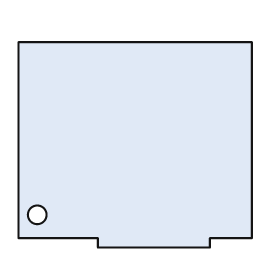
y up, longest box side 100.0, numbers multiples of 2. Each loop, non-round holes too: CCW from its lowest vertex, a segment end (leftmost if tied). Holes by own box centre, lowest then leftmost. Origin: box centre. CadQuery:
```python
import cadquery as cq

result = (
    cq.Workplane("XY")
    .moveTo(-16.0, -44.0)
    .lineTo(32.0, -44.0)
    .lineTo(32.0, -40.0)
    .lineTo(50.0, -40.0)
    .lineTo(50.0, 44.0)
    .lineTo(-50.0, 44.0)
    .lineTo(-50.0, -40.0)
    .lineTo(-16.0, -40.0)
    .close()
    .moveTo(-42.0, -30.0)
    .circle(4.0)
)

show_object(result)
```